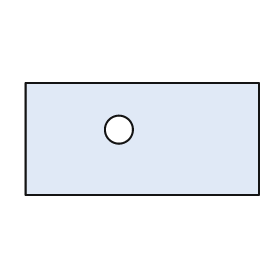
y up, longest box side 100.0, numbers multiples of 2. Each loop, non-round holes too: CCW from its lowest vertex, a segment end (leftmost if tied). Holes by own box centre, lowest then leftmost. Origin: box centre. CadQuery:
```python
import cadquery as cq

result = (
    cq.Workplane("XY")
    .moveTo(-50.0, -24.0)
    .lineTo(50.0, -24.0)
    .lineTo(50.0, 24.0)
    .lineTo(-50.0, 24.0)
    .close()
    .moveTo(-10.0, 4.0)
    .circle(6.0)
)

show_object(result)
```